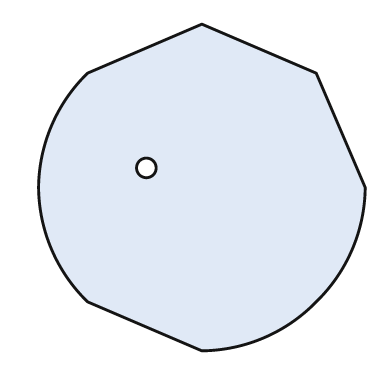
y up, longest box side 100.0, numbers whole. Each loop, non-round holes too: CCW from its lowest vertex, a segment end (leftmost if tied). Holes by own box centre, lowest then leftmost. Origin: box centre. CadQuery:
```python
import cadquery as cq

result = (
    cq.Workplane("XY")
    .moveTo(0.0, -50.0)
    .threePointArc((19.0, -46.0), (35.0, -35.0))
    .threePointArc((46.0, -19.0), (50.0, 0.0))
    .lineTo(35.0, 35.0)
    .lineTo(0.0, 50.0)
    .lineTo(-35.0, 35.0)
    .threePointArc((-46.0, 19.0), (-50.0, 0.0))
    .threePointArc((-46.0, -19.0), (-35.0, -35.0))
    .close()
    .moveTo(-17.0, 6.0)
    .circle(3.0)
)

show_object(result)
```